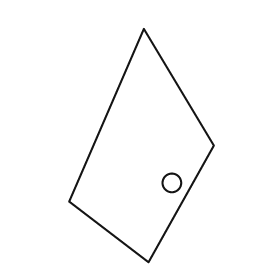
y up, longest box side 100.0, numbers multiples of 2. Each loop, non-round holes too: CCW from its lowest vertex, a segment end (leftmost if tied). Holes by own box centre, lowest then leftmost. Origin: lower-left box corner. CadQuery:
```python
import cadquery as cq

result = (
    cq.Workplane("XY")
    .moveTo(34.0, 0.0)
    .lineTo(62.0, 50.0)
    .lineTo(32.0, 100.0)
    .lineTo(0.0, 26.0)
    .close()
    .moveTo(44.0, 34.0)
    .circle(4.0)
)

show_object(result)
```